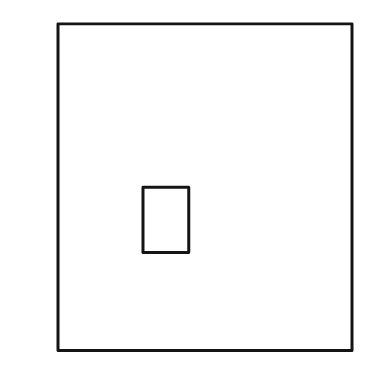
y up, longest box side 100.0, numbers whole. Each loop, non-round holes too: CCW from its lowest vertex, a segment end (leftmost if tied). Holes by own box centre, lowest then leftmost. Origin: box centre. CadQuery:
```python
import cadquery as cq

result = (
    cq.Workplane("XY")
    .moveTo(-45.0, -50.0)
    .lineTo(45.0, -50.0)
    .lineTo(45.0, 50.0)
    .lineTo(-45.0, 50.0)
    .close()
    .moveTo(-19.0, -20.0)
    .lineTo(-5.0, -20.0)
    .lineTo(-5.0, 0.0)
    .lineTo(-19.0, 0.0)
    .close()
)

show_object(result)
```